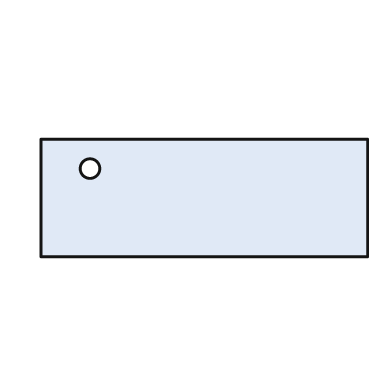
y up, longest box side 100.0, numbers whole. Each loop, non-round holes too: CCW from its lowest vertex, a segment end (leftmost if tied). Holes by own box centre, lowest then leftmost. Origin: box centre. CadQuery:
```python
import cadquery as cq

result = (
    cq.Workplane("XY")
    .moveTo(-50.0, -18.0)
    .lineTo(50.0, -18.0)
    .lineTo(50.0, 18.0)
    .lineTo(-50.0, 18.0)
    .close()
    .moveTo(-35.0, 9.0)
    .circle(3.0)
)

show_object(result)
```